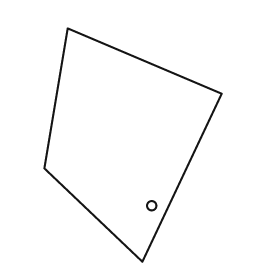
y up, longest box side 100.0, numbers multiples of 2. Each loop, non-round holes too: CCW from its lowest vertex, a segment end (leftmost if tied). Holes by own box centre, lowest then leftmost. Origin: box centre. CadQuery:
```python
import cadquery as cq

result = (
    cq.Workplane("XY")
    .moveTo(4.0, -50.0)
    .lineTo(38.0, 22.0)
    .lineTo(-28.0, 50.0)
    .lineTo(-38.0, -10.0)
    .close()
    .moveTo(8.0, -26.0)
    .circle(2.0)
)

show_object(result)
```